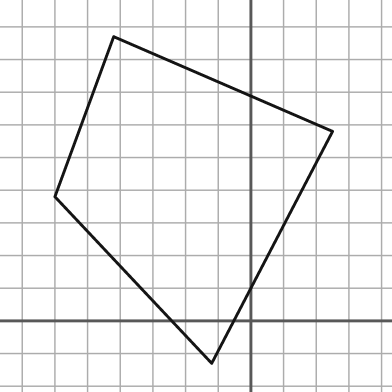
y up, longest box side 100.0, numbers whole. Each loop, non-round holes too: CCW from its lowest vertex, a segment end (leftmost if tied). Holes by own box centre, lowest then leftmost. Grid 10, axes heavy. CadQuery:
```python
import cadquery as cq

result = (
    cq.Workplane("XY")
    .moveTo(-12.0, -13.0)
    .lineTo(25.0, 58.0)
    .lineTo(-42.0, 87.0)
    .lineTo(-60.0, 38.0)
    .close()
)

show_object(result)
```